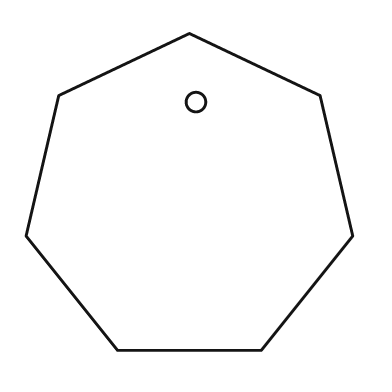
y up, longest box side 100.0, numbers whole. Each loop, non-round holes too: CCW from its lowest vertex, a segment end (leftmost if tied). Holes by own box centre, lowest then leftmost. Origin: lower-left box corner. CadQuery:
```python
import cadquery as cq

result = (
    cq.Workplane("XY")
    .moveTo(28.0, 0.0)
    .lineTo(72.0, 0.0)
    .lineTo(100.0, 35.0)
    .lineTo(90.0, 78.0)
    .lineTo(50.0, 97.0)
    .lineTo(10.0, 78.0)
    .lineTo(0.0, 35.0)
    .close()
    .moveTo(52.0, 76.0)
    .circle(3.0)
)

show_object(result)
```